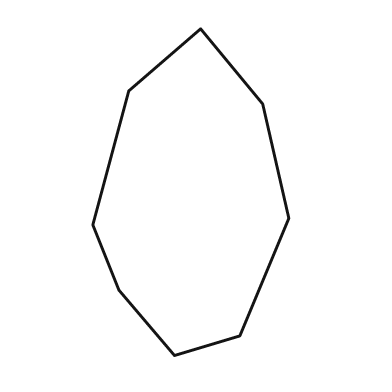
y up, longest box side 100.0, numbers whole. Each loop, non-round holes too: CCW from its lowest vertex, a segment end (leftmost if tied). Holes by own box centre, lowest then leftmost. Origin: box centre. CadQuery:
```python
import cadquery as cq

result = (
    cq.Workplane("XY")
    .moveTo(-5.0, -50.0)
    .lineTo(15.0, -44.0)
    .lineTo(30.0, -8.0)
    .lineTo(22.0, 27.0)
    .lineTo(3.0, 50.0)
    .lineTo(-19.0, 31.0)
    .lineTo(-30.0, -10.0)
    .lineTo(-22.0, -30.0)
    .close()
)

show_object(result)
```